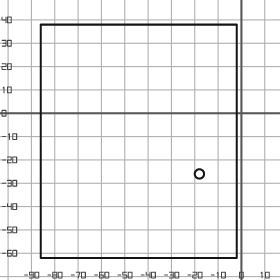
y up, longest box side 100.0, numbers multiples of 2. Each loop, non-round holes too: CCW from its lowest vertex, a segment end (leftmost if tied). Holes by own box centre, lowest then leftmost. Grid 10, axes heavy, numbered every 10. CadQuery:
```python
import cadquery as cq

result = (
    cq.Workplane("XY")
    .moveTo(-86.0, -62.0)
    .lineTo(-2.0, -62.0)
    .lineTo(-2.0, 38.0)
    .lineTo(-86.0, 38.0)
    .close()
    .moveTo(-18.0, -26.0)
    .circle(2.0)
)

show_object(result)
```